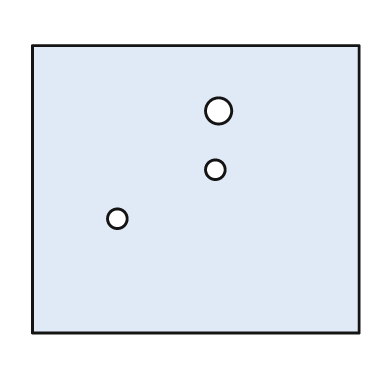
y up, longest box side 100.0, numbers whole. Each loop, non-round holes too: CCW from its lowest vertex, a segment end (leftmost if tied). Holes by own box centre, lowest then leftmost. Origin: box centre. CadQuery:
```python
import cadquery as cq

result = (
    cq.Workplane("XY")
    .moveTo(-50.0, -44.0)
    .lineTo(50.0, -44.0)
    .lineTo(50.0, 44.0)
    .lineTo(-50.0, 44.0)
    .close()
    .moveTo(-24.0, -9.0)
    .circle(3.0)
    .moveTo(6.0, 6.0)
    .circle(3.0)
    .moveTo(7.0, 24.0)
    .circle(4.0)
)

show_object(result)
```